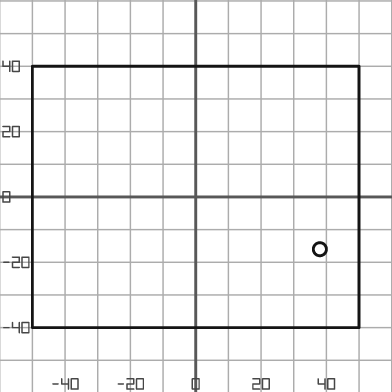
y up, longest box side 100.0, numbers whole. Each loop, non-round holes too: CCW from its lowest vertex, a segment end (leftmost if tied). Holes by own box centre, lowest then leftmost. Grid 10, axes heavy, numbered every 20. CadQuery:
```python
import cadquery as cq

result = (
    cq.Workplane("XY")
    .moveTo(-50.0, -40.0)
    .lineTo(50.0, -40.0)
    .lineTo(50.0, 40.0)
    .lineTo(-50.0, 40.0)
    .close()
    .moveTo(38.0, -16.0)
    .circle(2.0)
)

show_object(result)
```